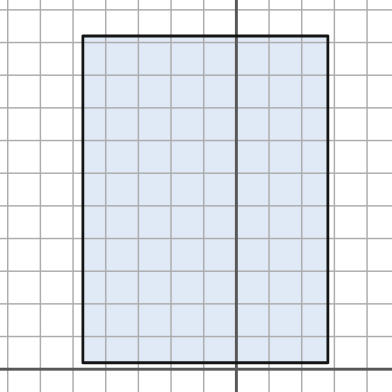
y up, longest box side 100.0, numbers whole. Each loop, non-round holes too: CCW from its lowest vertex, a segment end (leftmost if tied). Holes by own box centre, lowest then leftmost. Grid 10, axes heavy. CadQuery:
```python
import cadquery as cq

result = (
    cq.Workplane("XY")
    .moveTo(-47.0, 2.0)
    .lineTo(28.0, 2.0)
    .lineTo(28.0, 102.0)
    .lineTo(-47.0, 102.0)
    .close()
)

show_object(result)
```